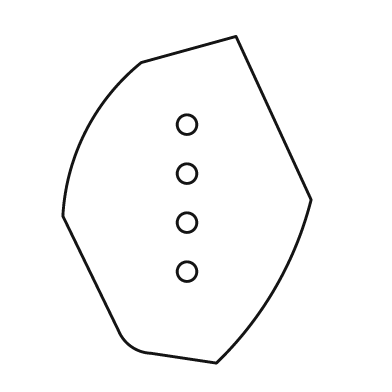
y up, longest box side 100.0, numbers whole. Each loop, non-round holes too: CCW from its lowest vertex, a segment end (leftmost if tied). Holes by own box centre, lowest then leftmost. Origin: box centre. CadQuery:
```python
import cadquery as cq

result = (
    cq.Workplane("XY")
    .moveTo(9.0, -50.0)
    .threePointArc((27.0, -27.0), (38.0, 0.0))
    .lineTo(15.0, 50.0)
    .lineTo(-14.0, 42.0)
    .threePointArc((-31.0, 21.0), (-38.0, -5.0))
    .lineTo(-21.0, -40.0)
    .threePointArc((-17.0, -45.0), (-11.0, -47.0))
    .close()
    .moveTo(0.0, -22.0)
    .circle(3.0)
    .moveTo(0.0, -7.0)
    .circle(3.0)
    .moveTo(0.0, 8.0)
    .circle(3.0)
    .moveTo(0.0, 23.0)
    .circle(3.0)
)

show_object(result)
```